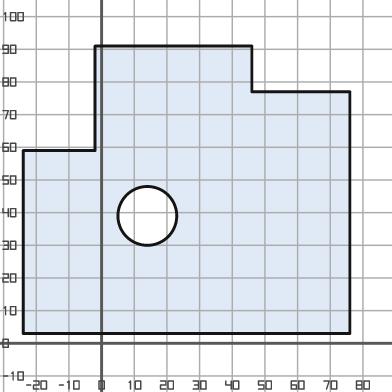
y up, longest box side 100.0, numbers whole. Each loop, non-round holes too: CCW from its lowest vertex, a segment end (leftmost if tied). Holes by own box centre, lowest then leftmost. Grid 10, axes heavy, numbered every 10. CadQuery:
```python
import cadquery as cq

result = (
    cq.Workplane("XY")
    .moveTo(-24.0, 3.0)
    .lineTo(76.0, 3.0)
    .lineTo(76.0, 77.0)
    .lineTo(46.0, 77.0)
    .lineTo(46.0, 91.0)
    .lineTo(-2.0, 91.0)
    .lineTo(-2.0, 59.0)
    .lineTo(-24.0, 59.0)
    .close()
    .moveTo(14.0, 39.0)
    .circle(9.0)
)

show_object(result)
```